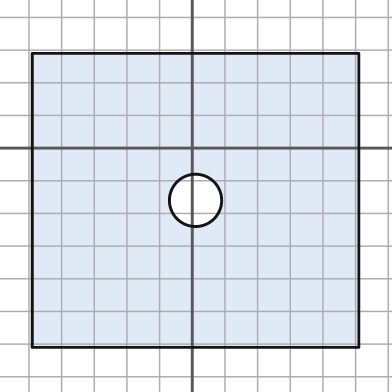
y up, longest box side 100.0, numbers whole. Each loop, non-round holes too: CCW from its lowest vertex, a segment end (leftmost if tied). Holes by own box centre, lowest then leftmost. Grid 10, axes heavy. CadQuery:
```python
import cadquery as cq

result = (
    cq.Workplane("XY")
    .moveTo(-49.0, -61.0)
    .lineTo(51.0, -61.0)
    .lineTo(51.0, 29.0)
    .lineTo(-49.0, 29.0)
    .close()
    .moveTo(1.0, -16.0)
    .circle(8.0)
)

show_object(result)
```